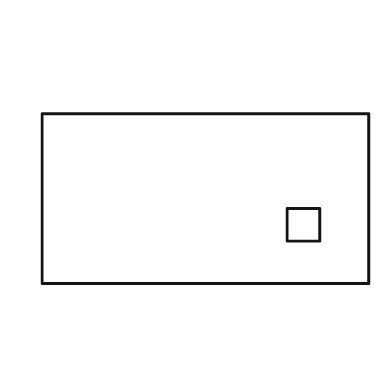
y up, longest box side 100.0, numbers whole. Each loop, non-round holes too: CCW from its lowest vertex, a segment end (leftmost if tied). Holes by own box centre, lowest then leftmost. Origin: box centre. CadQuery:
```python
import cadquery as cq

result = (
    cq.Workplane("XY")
    .moveTo(-50.0, -26.0)
    .lineTo(50.0, -26.0)
    .lineTo(50.0, 26.0)
    .lineTo(-50.0, 26.0)
    .close()
    .moveTo(25.0, -13.0)
    .lineTo(35.0, -13.0)
    .lineTo(35.0, -3.0)
    .lineTo(25.0, -3.0)
    .close()
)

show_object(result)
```